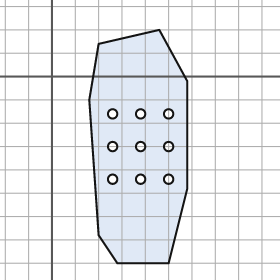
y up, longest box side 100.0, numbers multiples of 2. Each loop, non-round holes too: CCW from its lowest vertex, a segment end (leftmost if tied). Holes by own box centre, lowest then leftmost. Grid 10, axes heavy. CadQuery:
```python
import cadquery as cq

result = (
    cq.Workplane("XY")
    .moveTo(28.0, -80.0)
    .lineTo(50.0, -80.0)
    .lineTo(58.0, -48.0)
    .lineTo(58.0, -2.0)
    .lineTo(46.0, 20.0)
    .lineTo(20.0, 14.0)
    .lineTo(16.0, -10.0)
    .lineTo(20.0, -68.0)
    .close()
    .moveTo(26.0, -44.0)
    .circle(2.0)
    .moveTo(38.0, -44.0)
    .circle(2.0)
    .moveTo(50.0, -44.0)
    .circle(2.0)
    .moveTo(26.0, -30.0)
    .circle(2.0)
    .moveTo(38.0, -30.0)
    .circle(2.0)
    .moveTo(50.0, -30.0)
    .circle(2.0)
    .moveTo(26.0, -16.0)
    .circle(2.0)
    .moveTo(38.0, -16.0)
    .circle(2.0)
    .moveTo(50.0, -16.0)
    .circle(2.0)
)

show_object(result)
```